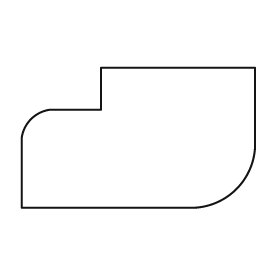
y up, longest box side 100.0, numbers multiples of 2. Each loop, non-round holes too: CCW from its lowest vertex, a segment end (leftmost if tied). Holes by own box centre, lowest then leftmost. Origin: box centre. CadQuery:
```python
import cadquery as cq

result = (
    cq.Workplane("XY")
    .moveTo(-50.0, -30.0)
    .lineTo(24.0, -30.0)
    .threePointArc((42.0, -22.0), (50.0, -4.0))
    .lineTo(50.0, 30.0)
    .lineTo(-16.0, 30.0)
    .lineTo(-16.0, 12.0)
    .lineTo(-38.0, 12.0)
    .threePointArc((-46.0, 8.0), (-50.0, 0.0))
    .close()
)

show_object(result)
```